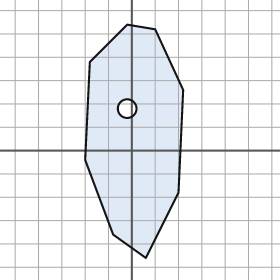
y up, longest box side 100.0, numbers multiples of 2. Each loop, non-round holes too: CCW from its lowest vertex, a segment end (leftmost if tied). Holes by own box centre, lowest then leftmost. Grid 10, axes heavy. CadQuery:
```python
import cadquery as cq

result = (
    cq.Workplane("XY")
    .moveTo(6.0, -46.0)
    .lineTo(20.0, -18.0)
    .lineTo(22.0, 26.0)
    .lineTo(10.0, 52.0)
    .lineTo(-2.0, 54.0)
    .lineTo(-18.0, 38.0)
    .lineTo(-20.0, -4.0)
    .lineTo(-8.0, -36.0)
    .close()
    .moveTo(-2.0, 18.0)
    .circle(4.0)
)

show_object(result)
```